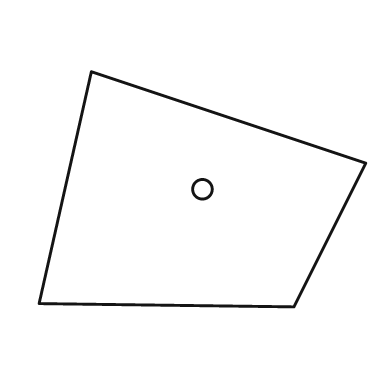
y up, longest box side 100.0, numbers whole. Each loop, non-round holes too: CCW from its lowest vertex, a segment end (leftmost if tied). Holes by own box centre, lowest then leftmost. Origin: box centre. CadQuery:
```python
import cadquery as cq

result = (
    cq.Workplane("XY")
    .moveTo(28.0, -36.0)
    .lineTo(50.0, 8.0)
    .lineTo(-34.0, 36.0)
    .lineTo(-50.0, -35.0)
    .close()
    .moveTo(0.0, 0.0)
    .circle(3.0)
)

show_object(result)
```